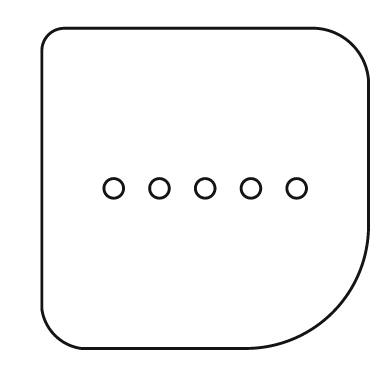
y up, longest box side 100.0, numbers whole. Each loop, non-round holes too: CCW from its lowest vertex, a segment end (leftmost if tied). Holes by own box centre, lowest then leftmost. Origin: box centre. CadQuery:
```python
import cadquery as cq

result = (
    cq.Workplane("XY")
    .moveTo(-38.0, -49.0)
    .lineTo(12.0, -49.0)
    .threePointArc((39.0, -38.0), (50.0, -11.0))
    .lineTo(50.0, 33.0)
    .threePointArc((45.0, 44.0), (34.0, 49.0))
    .lineTo(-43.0, 49.0)
    .threePointArc((-48.0, 47.0), (-50.0, 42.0))
    .lineTo(-50.0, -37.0)
    .threePointArc((-46.0, -45.0), (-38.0, -49.0))
    .close()
    .moveTo(-28.0, 0.0)
    .circle(3.0)
    .moveTo(-14.0, 0.0)
    .circle(3.0)
    .moveTo(0.0, 0.0)
    .circle(3.0)
    .moveTo(14.0, 0.0)
    .circle(3.0)
    .moveTo(28.0, 0.0)
    .circle(3.0)
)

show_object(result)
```